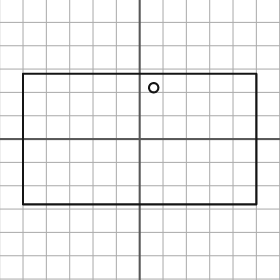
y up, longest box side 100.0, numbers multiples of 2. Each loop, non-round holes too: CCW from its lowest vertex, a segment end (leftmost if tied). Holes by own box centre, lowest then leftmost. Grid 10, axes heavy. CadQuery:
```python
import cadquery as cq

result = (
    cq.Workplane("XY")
    .moveTo(-50.0, -28.0)
    .lineTo(50.0, -28.0)
    .lineTo(50.0, 28.0)
    .lineTo(-50.0, 28.0)
    .close()
    .moveTo(6.0, 22.0)
    .circle(2.0)
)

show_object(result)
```